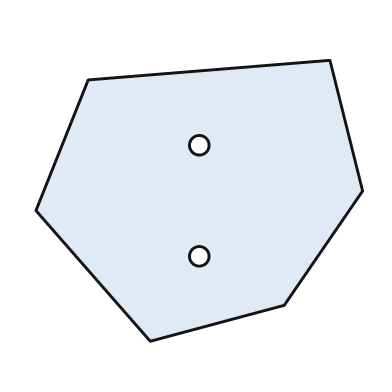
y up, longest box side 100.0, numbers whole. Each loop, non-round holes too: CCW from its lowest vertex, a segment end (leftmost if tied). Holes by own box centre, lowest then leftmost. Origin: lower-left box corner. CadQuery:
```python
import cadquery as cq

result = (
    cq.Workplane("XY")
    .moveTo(35.0, 0.0)
    .lineTo(76.0, 11.0)
    .lineTo(100.0, 46.0)
    .lineTo(90.0, 86.0)
    .lineTo(16.0, 80.0)
    .lineTo(0.0, 40.0)
    .close()
    .moveTo(50.0, 26.0)
    .circle(3.0)
    .moveTo(50.0, 60.0)
    .circle(3.0)
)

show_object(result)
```